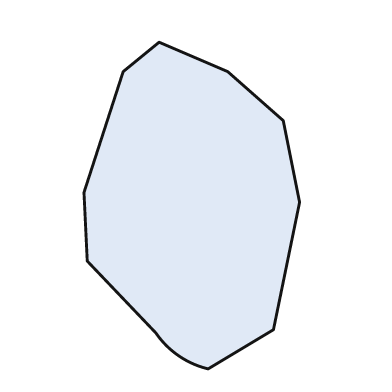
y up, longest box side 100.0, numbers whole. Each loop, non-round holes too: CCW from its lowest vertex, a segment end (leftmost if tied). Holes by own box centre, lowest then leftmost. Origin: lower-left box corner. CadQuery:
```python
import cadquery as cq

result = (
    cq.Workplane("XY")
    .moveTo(38.0, 0.0)
    .lineTo(58.0, 12.0)
    .lineTo(66.0, 51.0)
    .lineTo(61.0, 76.0)
    .lineTo(44.0, 91.0)
    .lineTo(23.0, 100.0)
    .lineTo(12.0, 91.0)
    .lineTo(0.0, 54.0)
    .lineTo(1.0, 33.0)
    .lineTo(22.0, 11.0)
    .threePointArc((29.0, 4.0), (38.0, 0.0))
    .close()
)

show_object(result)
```